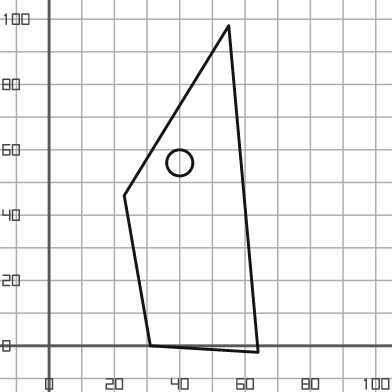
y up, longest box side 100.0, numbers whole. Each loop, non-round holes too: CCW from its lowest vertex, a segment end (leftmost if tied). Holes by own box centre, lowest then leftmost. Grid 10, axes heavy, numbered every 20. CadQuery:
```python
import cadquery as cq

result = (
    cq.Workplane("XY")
    .moveTo(64.0, -2.0)
    .lineTo(55.0, 98.0)
    .lineTo(23.0, 46.0)
    .lineTo(31.0, 0.0)
    .close()
    .moveTo(40.0, 56.0)
    .circle(4.0)
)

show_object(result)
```